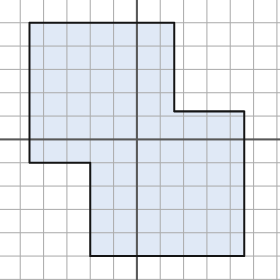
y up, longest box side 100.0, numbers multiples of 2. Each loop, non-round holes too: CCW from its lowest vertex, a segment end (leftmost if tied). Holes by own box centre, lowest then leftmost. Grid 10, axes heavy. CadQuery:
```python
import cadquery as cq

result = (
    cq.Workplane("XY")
    .moveTo(-20.0, -50.0)
    .lineTo(46.0, -50.0)
    .lineTo(46.0, 12.0)
    .lineTo(16.0, 12.0)
    .lineTo(16.0, 50.0)
    .lineTo(-46.0, 50.0)
    .lineTo(-46.0, -10.0)
    .lineTo(-20.0, -10.0)
    .close()
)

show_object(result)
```